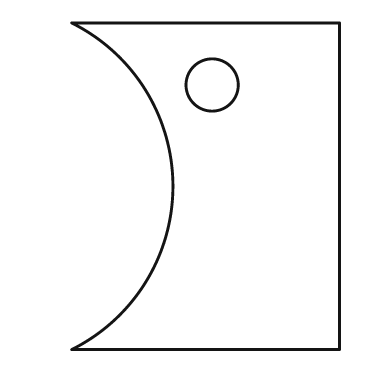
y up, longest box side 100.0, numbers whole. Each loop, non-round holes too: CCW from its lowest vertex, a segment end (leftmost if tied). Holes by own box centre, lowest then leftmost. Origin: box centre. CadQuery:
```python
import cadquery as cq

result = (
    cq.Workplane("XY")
    .moveTo(-41.0, -50.0)
    .lineTo(41.0, -50.0)
    .lineTo(41.0, 50.0)
    .lineTo(-41.0, 50.0)
    .threePointArc((-10.0, 0.0), (-41.0, -50.0))
    .close()
    .moveTo(2.0, 31.0)
    .circle(8.0)
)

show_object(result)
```